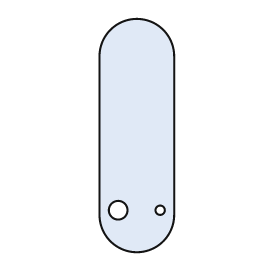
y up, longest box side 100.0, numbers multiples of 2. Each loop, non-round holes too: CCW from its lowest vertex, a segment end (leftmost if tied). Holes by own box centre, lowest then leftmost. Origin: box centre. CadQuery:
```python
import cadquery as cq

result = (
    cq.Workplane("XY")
    .moveTo(-16.0, -34.0)
    .threePointArc((0.0, -50.0), (16.0, -34.0))
    .lineTo(16.0, 34.0)
    .threePointArc((0.0, 50.0), (-16.0, 34.0))
    .close()
    .moveTo(-8.0, -32.0)
    .circle(4.0)
    .moveTo(10.0, -32.0)
    .circle(2.0)
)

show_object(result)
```